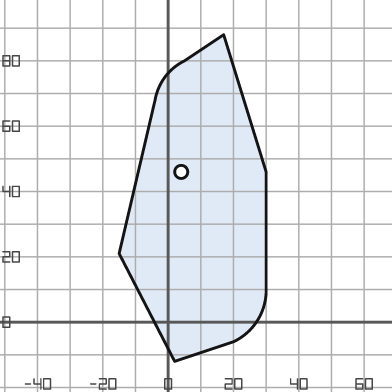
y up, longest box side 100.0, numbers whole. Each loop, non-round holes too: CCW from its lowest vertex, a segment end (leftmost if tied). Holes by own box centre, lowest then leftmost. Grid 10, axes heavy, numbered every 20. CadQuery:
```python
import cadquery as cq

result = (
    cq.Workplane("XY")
    .moveTo(2.0, -12.0)
    .lineTo(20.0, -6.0)
    .threePointArc((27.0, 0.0), (30.0, 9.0))
    .lineTo(30.0, 46.0)
    .lineTo(17.0, 88.0)
    .lineTo(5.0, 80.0)
    .threePointArc((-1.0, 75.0), (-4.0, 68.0))
    .lineTo(-15.0, 21.0)
    .close()
    .moveTo(4.0, 46.0)
    .circle(2.0)
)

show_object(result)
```